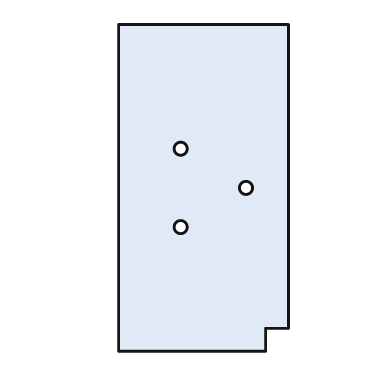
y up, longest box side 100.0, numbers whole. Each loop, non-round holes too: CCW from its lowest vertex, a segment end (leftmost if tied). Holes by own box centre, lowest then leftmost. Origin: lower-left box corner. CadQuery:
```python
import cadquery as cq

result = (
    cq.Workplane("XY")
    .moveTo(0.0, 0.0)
    .lineTo(45.0, 0.0)
    .lineTo(45.0, 7.0)
    .lineTo(52.0, 7.0)
    .lineTo(52.0, 100.0)
    .lineTo(0.0, 100.0)
    .close()
    .moveTo(19.0, 38.0)
    .circle(2.0)
    .moveTo(39.0, 50.0)
    .circle(2.0)
    .moveTo(19.0, 62.0)
    .circle(2.0)
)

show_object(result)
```